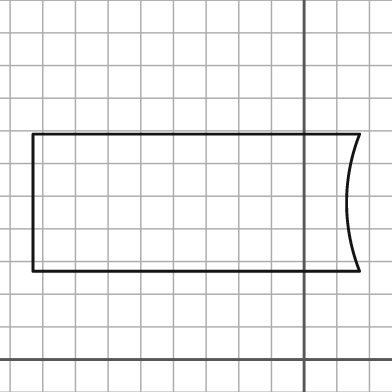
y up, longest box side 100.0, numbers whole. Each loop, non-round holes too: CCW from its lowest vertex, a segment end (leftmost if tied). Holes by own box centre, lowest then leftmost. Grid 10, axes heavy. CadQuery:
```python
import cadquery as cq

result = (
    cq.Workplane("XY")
    .moveTo(-83.0, 27.0)
    .lineTo(17.0, 27.0)
    .threePointArc((13.0, 48.0), (17.0, 69.0))
    .lineTo(-83.0, 69.0)
    .close()
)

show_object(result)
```